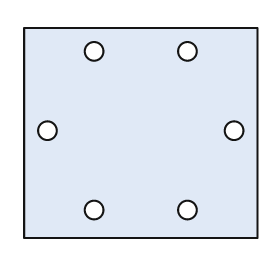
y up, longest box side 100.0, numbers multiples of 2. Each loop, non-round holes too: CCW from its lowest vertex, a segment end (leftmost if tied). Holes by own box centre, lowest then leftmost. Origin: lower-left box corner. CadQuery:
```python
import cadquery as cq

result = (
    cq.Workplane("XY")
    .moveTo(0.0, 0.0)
    .lineTo(100.0, 0.0)
    .lineTo(100.0, 90.0)
    .lineTo(0.0, 90.0)
    .close()
    .moveTo(30.0, 12.0)
    .circle(4.0)
    .moveTo(70.0, 12.0)
    .circle(4.0)
    .moveTo(10.0, 46.0)
    .circle(4.0)
    .moveTo(90.0, 46.0)
    .circle(4.0)
    .moveTo(30.0, 80.0)
    .circle(4.0)
    .moveTo(70.0, 80.0)
    .circle(4.0)
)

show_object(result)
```